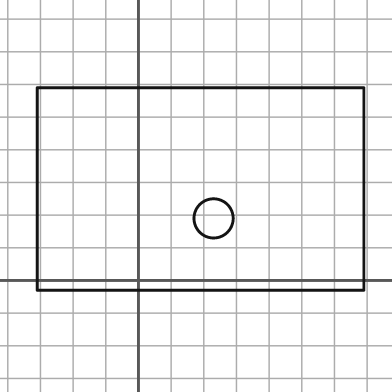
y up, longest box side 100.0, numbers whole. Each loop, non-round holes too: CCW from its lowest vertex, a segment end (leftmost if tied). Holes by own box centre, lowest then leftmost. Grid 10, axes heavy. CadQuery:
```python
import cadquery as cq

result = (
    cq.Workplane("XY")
    .moveTo(-31.0, -3.0)
    .lineTo(69.0, -3.0)
    .lineTo(69.0, 59.0)
    .lineTo(-31.0, 59.0)
    .close()
    .moveTo(23.0, 19.0)
    .circle(6.0)
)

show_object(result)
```